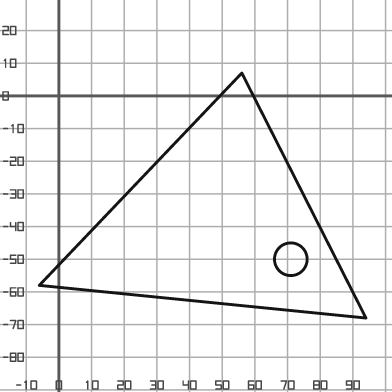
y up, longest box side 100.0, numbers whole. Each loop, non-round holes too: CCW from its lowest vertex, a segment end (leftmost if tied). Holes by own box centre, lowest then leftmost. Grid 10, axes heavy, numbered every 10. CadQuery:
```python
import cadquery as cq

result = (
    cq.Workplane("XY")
    .moveTo(94.0, -68.0)
    .lineTo(56.0, 7.0)
    .lineTo(-6.0, -58.0)
    .close()
    .moveTo(71.0, -50.0)
    .circle(5.0)
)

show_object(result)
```